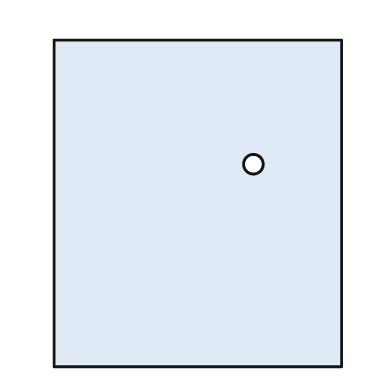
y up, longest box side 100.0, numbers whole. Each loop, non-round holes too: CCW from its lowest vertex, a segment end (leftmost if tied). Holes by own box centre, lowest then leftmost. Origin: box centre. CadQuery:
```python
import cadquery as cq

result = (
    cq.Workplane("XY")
    .moveTo(-44.0, -50.0)
    .lineTo(44.0, -50.0)
    .lineTo(44.0, 50.0)
    .lineTo(-44.0, 50.0)
    .close()
    .moveTo(17.0, 12.0)
    .circle(3.0)
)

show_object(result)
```